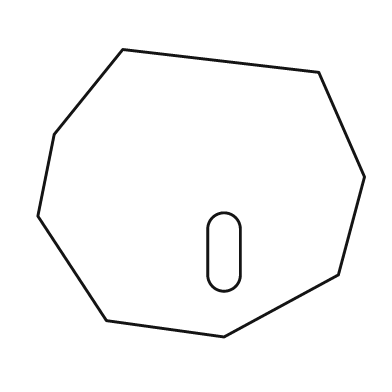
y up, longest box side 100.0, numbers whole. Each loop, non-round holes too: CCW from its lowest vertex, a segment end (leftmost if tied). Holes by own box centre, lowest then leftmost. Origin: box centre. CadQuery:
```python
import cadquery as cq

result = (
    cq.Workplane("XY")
    .moveTo(7.0, -44.0)
    .lineTo(42.0, -25.0)
    .lineTo(50.0, 5.0)
    .lineTo(36.0, 37.0)
    .lineTo(-24.0, 44.0)
    .lineTo(-45.0, 18.0)
    .lineTo(-50.0, -7.0)
    .lineTo(-29.0, -39.0)
    .close()
    .moveTo(2.0, -25.0)
    .threePointArc((7.0, -30.0), (12.0, -25.0))
    .lineTo(12.0, -11.0)
    .threePointArc((7.0, -6.0), (2.0, -11.0))
    .close()
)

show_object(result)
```